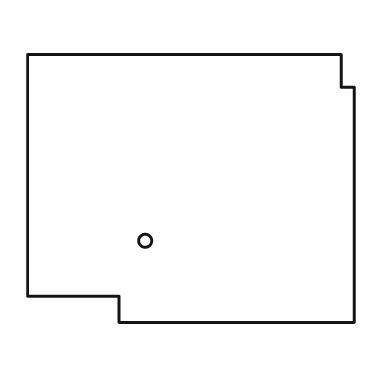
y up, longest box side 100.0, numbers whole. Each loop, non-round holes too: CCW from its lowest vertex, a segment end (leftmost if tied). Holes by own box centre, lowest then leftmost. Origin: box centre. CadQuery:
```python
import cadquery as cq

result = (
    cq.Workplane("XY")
    .moveTo(-22.0, -41.0)
    .lineTo(50.0, -41.0)
    .lineTo(50.0, 31.0)
    .lineTo(46.0, 31.0)
    .lineTo(46.0, 41.0)
    .lineTo(-50.0, 41.0)
    .lineTo(-50.0, -33.0)
    .lineTo(-22.0, -33.0)
    .close()
    .moveTo(-14.0, -16.0)
    .circle(2.0)
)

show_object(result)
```